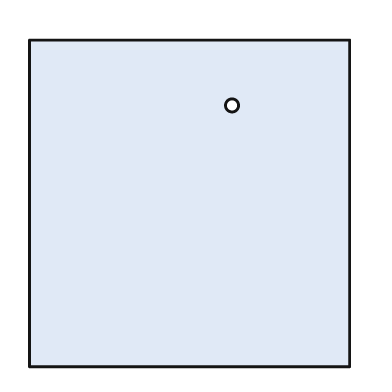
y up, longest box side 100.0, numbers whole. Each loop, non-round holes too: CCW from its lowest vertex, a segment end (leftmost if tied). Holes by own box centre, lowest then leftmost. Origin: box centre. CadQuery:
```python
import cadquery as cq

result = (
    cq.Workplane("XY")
    .moveTo(-49.0, -50.0)
    .lineTo(49.0, -50.0)
    .lineTo(49.0, 50.0)
    .lineTo(-49.0, 50.0)
    .close()
    .moveTo(13.0, 30.0)
    .circle(2.0)
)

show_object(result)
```